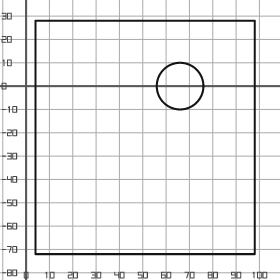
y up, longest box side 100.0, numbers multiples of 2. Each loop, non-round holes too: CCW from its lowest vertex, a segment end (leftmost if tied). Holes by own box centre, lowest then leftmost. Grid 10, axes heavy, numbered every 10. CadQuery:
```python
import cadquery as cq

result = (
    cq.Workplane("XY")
    .moveTo(4.0, -72.0)
    .lineTo(98.0, -72.0)
    .lineTo(98.0, 28.0)
    .lineTo(4.0, 28.0)
    .close()
    .moveTo(66.0, 0.0)
    .circle(10.0)
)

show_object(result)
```